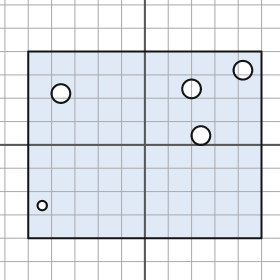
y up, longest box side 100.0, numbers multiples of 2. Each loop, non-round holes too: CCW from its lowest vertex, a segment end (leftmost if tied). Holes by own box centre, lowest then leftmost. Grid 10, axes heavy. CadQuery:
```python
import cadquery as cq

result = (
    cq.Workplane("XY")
    .moveTo(-50.0, -40.0)
    .lineTo(50.0, -40.0)
    .lineTo(50.0, 40.0)
    .lineTo(-50.0, 40.0)
    .close()
    .moveTo(-44.0, -26.0)
    .circle(2.0)
    .moveTo(24.0, 4.0)
    .circle(4.0)
    .moveTo(-36.0, 22.0)
    .circle(4.0)
    .moveTo(20.0, 24.0)
    .circle(4.0)
    .moveTo(42.0, 32.0)
    .circle(4.0)
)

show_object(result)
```